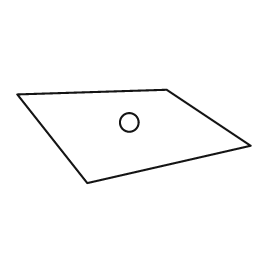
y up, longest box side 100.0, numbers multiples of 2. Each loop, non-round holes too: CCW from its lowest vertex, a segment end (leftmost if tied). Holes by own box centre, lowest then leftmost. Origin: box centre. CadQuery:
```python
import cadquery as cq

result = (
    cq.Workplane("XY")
    .moveTo(-20.0, -20.0)
    .lineTo(50.0, -4.0)
    .lineTo(14.0, 20.0)
    .lineTo(-50.0, 18.0)
    .close()
    .moveTo(-2.0, 6.0)
    .circle(4.0)
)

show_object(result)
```